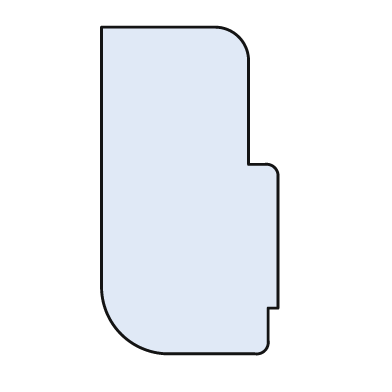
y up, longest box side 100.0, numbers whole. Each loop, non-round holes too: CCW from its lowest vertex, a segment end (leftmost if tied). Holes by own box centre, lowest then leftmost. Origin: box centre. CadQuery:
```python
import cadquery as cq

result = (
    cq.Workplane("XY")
    .moveTo(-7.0, -50.0)
    .lineTo(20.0, -50.0)
    .threePointArc((23.0, -49.0), (24.0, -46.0))
    .lineTo(24.0, -36.0)
    .lineTo(27.0, -36.0)
    .lineTo(27.0, 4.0)
    .threePointArc((26.0, 7.0), (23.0, 8.0))
    .lineTo(18.0, 8.0)
    .lineTo(18.0, 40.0)
    .threePointArc((15.0, 47.0), (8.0, 50.0))
    .lineTo(-27.0, 50.0)
    .lineTo(-27.0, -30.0)
    .threePointArc((-21.0, -44.0), (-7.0, -50.0))
    .close()
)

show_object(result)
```